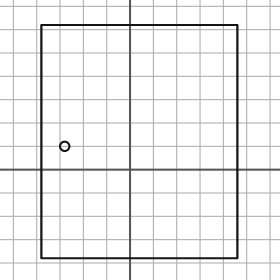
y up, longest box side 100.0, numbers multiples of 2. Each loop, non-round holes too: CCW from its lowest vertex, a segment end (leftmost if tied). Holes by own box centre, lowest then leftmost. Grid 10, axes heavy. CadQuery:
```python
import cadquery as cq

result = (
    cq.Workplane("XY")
    .moveTo(-38.0, -38.0)
    .lineTo(46.0, -38.0)
    .lineTo(46.0, 62.0)
    .lineTo(-38.0, 62.0)
    .close()
    .moveTo(-28.0, 10.0)
    .circle(2.0)
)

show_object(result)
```